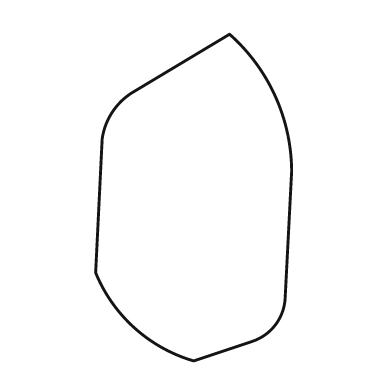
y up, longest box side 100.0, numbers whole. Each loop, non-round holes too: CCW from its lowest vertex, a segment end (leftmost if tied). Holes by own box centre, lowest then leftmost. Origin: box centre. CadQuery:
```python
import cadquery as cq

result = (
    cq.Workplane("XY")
    .moveTo(0.0, -50.0)
    .lineTo(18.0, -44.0)
    .threePointArc((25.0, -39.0), (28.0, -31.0))
    .lineTo(30.0, 8.0)
    .threePointArc((25.0, 31.0), (11.0, 50.0))
    .lineTo(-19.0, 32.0)
    .threePointArc((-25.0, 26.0), (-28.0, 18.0))
    .lineTo(-30.0, -23.0)
    .threePointArc((-18.0, -40.0), (0.0, -50.0))
    .close()
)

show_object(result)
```